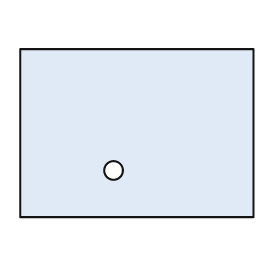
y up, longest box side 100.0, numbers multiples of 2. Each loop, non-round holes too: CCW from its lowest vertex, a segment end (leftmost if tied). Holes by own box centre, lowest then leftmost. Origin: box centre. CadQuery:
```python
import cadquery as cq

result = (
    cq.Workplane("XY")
    .moveTo(-50.0, -36.0)
    .lineTo(50.0, -36.0)
    .lineTo(50.0, 36.0)
    .lineTo(-50.0, 36.0)
    .close()
    .moveTo(-10.0, -16.0)
    .circle(4.0)
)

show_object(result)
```